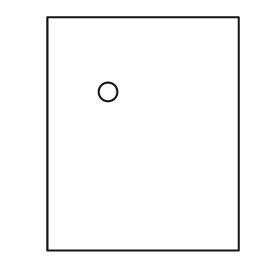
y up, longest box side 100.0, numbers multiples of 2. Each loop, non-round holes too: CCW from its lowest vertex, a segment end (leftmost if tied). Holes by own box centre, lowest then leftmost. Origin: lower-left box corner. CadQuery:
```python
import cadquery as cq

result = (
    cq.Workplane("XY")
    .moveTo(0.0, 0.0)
    .lineTo(82.0, 0.0)
    .lineTo(82.0, 100.0)
    .lineTo(0.0, 100.0)
    .close()
    .moveTo(26.0, 68.0)
    .circle(4.0)
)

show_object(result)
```